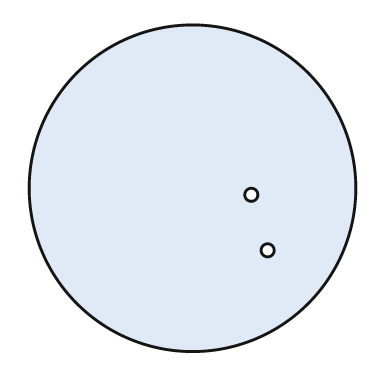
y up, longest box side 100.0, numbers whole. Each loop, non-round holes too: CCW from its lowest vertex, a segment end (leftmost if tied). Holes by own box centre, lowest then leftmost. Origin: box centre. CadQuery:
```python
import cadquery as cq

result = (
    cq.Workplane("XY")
    .moveTo(0.0, 0.0)
    .circle(50.0)
    .moveTo(23.0, -19.0)
    .circle(2.0)
    .moveTo(18.0, -2.0)
    .circle(2.0)
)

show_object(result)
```